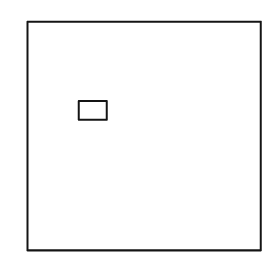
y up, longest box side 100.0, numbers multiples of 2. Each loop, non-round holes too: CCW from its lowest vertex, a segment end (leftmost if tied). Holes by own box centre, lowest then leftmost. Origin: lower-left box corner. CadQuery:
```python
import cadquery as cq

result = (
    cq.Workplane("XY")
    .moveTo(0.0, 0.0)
    .lineTo(100.0, 0.0)
    .lineTo(100.0, 98.0)
    .lineTo(0.0, 98.0)
    .close()
    .moveTo(22.0, 56.0)
    .lineTo(34.0, 56.0)
    .lineTo(34.0, 64.0)
    .lineTo(22.0, 64.0)
    .close()
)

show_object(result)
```